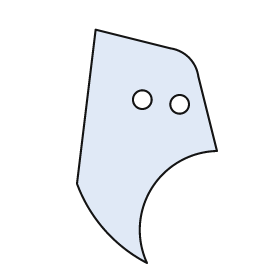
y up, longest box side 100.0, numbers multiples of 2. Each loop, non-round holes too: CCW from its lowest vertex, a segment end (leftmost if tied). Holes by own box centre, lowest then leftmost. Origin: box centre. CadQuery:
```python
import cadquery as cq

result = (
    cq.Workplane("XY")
    .moveTo(0.0, -50.0)
    .threePointArc((2.0, -18.0), (30.0, -2.0))
    .lineTo(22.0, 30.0)
    .threePointArc((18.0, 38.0), (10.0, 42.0))
    .lineTo(-22.0, 50.0)
    .lineTo(-30.0, -16.0)
    .threePointArc((-18.0, -36.0), (0.0, -50.0))
    .close()
    .moveTo(14.0, 18.0)
    .circle(4.0)
    .moveTo(-2.0, 20.0)
    .circle(4.0)
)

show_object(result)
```